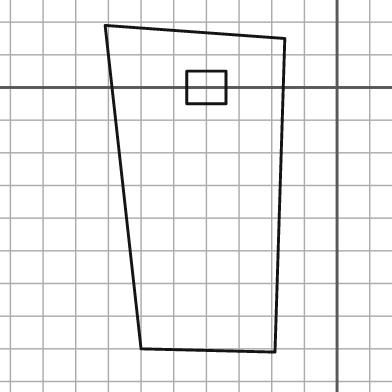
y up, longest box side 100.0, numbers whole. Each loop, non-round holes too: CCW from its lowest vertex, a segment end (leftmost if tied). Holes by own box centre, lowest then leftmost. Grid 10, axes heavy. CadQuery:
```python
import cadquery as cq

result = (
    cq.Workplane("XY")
    .moveTo(-19.0, -81.0)
    .lineTo(-16.0, 15.0)
    .lineTo(-71.0, 19.0)
    .lineTo(-60.0, -80.0)
    .close()
    .moveTo(-46.0, -5.0)
    .lineTo(-34.0, -5.0)
    .lineTo(-34.0, 5.0)
    .lineTo(-46.0, 5.0)
    .close()
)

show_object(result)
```